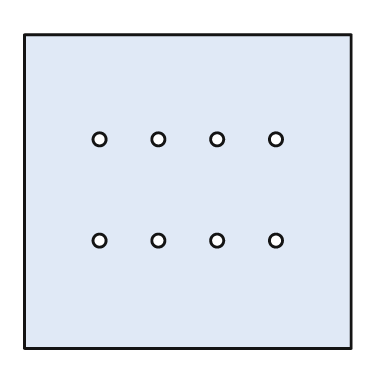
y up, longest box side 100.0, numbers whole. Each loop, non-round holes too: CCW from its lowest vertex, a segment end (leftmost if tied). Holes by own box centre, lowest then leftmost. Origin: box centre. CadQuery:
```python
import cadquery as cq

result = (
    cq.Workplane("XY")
    .moveTo(-50.0, -48.0)
    .lineTo(50.0, -48.0)
    .lineTo(50.0, 48.0)
    .lineTo(-50.0, 48.0)
    .close()
    .moveTo(-27.0, -15.0)
    .circle(2.0)
    .moveTo(-9.0, -15.0)
    .circle(2.0)
    .moveTo(9.0, -15.0)
    .circle(2.0)
    .moveTo(27.0, -15.0)
    .circle(2.0)
    .moveTo(-27.0, 16.0)
    .circle(2.0)
    .moveTo(-9.0, 16.0)
    .circle(2.0)
    .moveTo(9.0, 16.0)
    .circle(2.0)
    .moveTo(27.0, 16.0)
    .circle(2.0)
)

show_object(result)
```